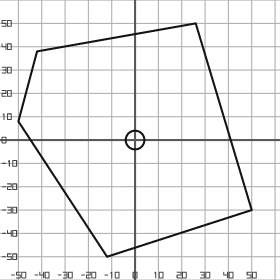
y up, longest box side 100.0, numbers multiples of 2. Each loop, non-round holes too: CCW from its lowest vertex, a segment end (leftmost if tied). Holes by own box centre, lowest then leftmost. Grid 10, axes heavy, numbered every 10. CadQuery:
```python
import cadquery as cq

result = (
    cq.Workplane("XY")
    .moveTo(-12.0, -50.0)
    .lineTo(50.0, -30.0)
    .lineTo(26.0, 50.0)
    .lineTo(-42.0, 38.0)
    .lineTo(-50.0, 8.0)
    .close()
    .moveTo(0.0, 0.0)
    .circle(4.0)
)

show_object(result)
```